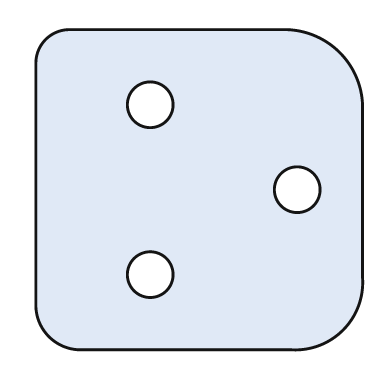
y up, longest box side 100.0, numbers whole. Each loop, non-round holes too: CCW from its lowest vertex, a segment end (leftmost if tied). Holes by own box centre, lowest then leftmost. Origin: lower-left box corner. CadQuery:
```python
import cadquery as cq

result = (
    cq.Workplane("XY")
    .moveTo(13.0, 0.0)
    .lineTo(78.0, 0.0)
    .threePointArc((94.0, 6.0), (100.0, 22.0))
    .lineTo(100.0, 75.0)
    .threePointArc((93.0, 91.0), (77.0, 98.0))
    .lineTo(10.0, 98.0)
    .threePointArc((3.0, 95.0), (0.0, 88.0))
    .lineTo(0.0, 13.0)
    .threePointArc((4.0, 4.0), (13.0, 0.0))
    .close()
    .moveTo(35.0, 23.0)
    .circle(7.0)
    .moveTo(80.0, 49.0)
    .circle(7.0)
    .moveTo(35.0, 75.0)
    .circle(7.0)
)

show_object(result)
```